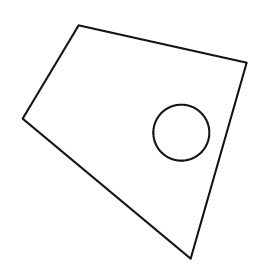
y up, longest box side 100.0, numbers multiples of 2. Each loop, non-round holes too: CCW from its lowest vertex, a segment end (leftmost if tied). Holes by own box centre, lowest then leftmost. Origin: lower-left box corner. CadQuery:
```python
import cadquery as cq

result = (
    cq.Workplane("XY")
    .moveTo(72.0, 0.0)
    .lineTo(96.0, 84.0)
    .lineTo(24.0, 100.0)
    .lineTo(0.0, 60.0)
    .close()
    .moveTo(68.0, 54.0)
    .circle(12.0)
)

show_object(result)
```